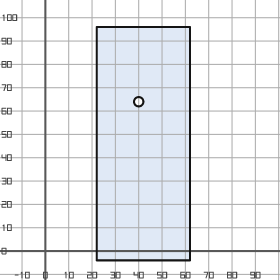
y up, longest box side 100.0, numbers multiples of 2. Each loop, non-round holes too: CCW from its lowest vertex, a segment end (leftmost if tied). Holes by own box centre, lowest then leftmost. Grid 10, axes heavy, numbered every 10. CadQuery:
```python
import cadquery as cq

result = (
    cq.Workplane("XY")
    .moveTo(22.0, -4.0)
    .lineTo(62.0, -4.0)
    .lineTo(62.0, 96.0)
    .lineTo(22.0, 96.0)
    .close()
    .moveTo(40.0, 64.0)
    .circle(2.0)
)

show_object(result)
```